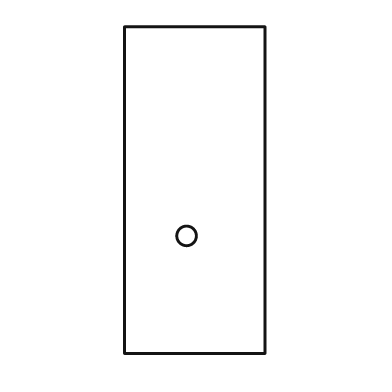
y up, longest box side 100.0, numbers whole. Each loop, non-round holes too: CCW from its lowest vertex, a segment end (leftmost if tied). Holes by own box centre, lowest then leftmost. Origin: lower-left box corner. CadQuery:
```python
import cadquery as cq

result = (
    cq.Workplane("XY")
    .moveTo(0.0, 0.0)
    .lineTo(43.0, 0.0)
    .lineTo(43.0, 100.0)
    .lineTo(0.0, 100.0)
    .close()
    .moveTo(19.0, 36.0)
    .circle(3.0)
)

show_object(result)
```